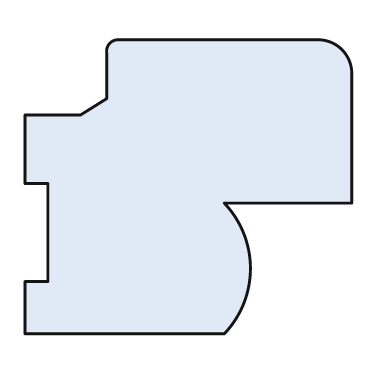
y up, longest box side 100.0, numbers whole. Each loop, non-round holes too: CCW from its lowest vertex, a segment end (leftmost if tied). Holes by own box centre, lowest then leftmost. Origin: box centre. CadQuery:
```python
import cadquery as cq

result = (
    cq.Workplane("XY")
    .moveTo(-50.0, -45.0)
    .lineTo(11.0, -45.0)
    .threePointArc((19.0, -25.0), (11.0, -5.0))
    .lineTo(50.0, -5.0)
    .lineTo(50.0, 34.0)
    .threePointArc((47.0, 42.0), (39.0, 45.0))
    .lineTo(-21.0, 45.0)
    .threePointArc((-24.0, 44.0), (-25.0, 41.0))
    .lineTo(-25.0, 27.0)
    .lineTo(-33.0, 22.0)
    .lineTo(-50.0, 22.0)
    .lineTo(-50.0, 1.0)
    .lineTo(-43.0, 1.0)
    .lineTo(-43.0, -29.0)
    .lineTo(-50.0, -29.0)
    .close()
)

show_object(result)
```